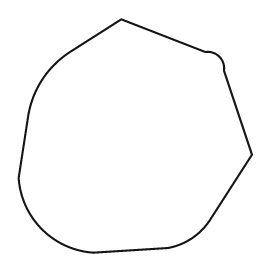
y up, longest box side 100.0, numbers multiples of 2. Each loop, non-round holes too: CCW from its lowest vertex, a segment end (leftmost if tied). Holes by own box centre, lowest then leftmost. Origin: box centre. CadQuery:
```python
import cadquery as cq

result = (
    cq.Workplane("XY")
    .moveTo(-18.0, -50.0)
    .lineTo(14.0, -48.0)
    .threePointArc((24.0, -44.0), (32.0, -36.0))
    .lineTo(50.0, -8.0)
    .lineTo(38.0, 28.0)
    .threePointArc((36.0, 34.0), (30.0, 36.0))
    .lineTo(-6.0, 50.0)
    .lineTo(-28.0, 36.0)
    .threePointArc((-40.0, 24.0), (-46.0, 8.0))
    .lineTo(-50.0, -18.0)
    .threePointArc((-40.0, -40.0), (-18.0, -50.0))
    .close()
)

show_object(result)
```